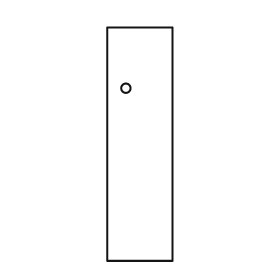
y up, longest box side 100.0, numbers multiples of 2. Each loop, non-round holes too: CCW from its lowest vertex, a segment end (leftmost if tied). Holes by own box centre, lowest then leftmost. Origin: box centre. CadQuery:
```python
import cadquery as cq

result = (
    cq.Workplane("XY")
    .moveTo(-14.0, -50.0)
    .lineTo(14.0, -50.0)
    .lineTo(14.0, 50.0)
    .lineTo(-14.0, 50.0)
    .close()
    .moveTo(-6.0, 24.0)
    .circle(2.0)
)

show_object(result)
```